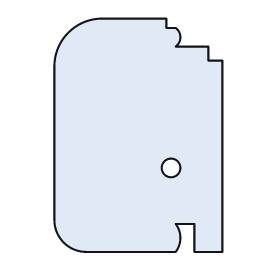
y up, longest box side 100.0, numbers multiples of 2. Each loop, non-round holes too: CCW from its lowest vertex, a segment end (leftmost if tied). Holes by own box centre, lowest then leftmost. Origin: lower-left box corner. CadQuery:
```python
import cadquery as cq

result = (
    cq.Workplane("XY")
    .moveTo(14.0, 0.0)
    .lineTo(52.0, 0.0)
    .threePointArc((54.0, 6.0), (52.0, 12.0))
    .lineTo(60.0, 12.0)
    .lineTo(60.0, 0.0)
    .lineTo(72.0, 0.0)
    .lineTo(72.0, 82.0)
    .lineTo(66.0, 82.0)
    .lineTo(66.0, 88.0)
    .lineTo(52.0, 88.0)
    .threePointArc((54.0, 92.0), (52.0, 96.0))
    .lineTo(48.0, 96.0)
    .lineTo(48.0, 100.0)
    .lineTo(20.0, 100.0)
    .threePointArc((6.0, 94.0), (0.0, 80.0))
    .lineTo(0.0, 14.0)
    .threePointArc((4.0, 4.0), (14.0, 0.0))
    .close()
    .moveTo(50.0, 36.0)
    .circle(4.0)
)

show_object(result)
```